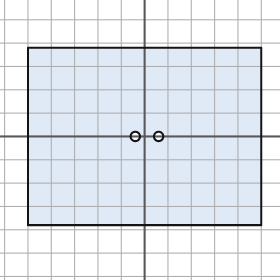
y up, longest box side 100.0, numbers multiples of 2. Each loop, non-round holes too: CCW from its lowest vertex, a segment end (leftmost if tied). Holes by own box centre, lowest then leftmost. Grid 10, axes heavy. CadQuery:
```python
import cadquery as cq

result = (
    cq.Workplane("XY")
    .moveTo(-50.0, -38.0)
    .lineTo(50.0, -38.0)
    .lineTo(50.0, 38.0)
    .lineTo(-50.0, 38.0)
    .close()
    .moveTo(-4.0, 0.0)
    .circle(2.0)
    .moveTo(6.0, 0.0)
    .circle(2.0)
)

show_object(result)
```